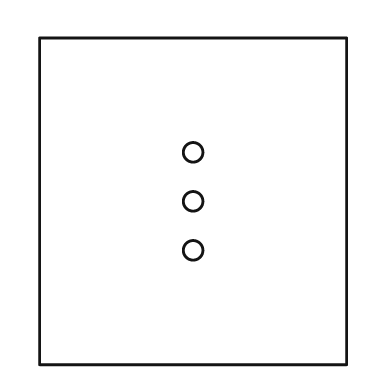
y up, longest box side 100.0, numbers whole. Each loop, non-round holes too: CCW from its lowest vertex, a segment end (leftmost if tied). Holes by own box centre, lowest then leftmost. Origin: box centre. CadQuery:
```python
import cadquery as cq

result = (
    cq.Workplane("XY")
    .moveTo(-47.0, -50.0)
    .lineTo(47.0, -50.0)
    .lineTo(47.0, 50.0)
    .lineTo(-47.0, 50.0)
    .close()
    .moveTo(0.0, -15.0)
    .circle(3.0)
    .moveTo(0.0, 0.0)
    .circle(3.0)
    .moveTo(0.0, 15.0)
    .circle(3.0)
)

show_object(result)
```